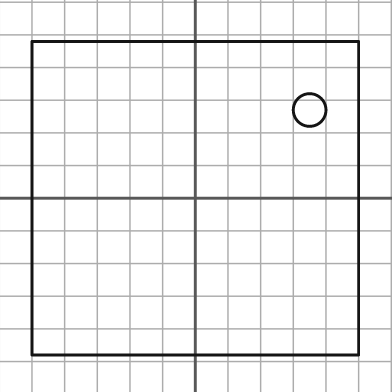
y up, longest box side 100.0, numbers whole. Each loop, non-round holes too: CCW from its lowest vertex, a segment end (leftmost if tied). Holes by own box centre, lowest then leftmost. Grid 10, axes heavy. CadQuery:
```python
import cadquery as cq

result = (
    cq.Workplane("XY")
    .moveTo(-50.0, -48.0)
    .lineTo(50.0, -48.0)
    .lineTo(50.0, 48.0)
    .lineTo(-50.0, 48.0)
    .close()
    .moveTo(35.0, 27.0)
    .circle(5.0)
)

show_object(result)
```